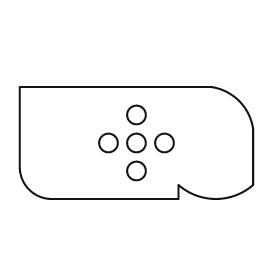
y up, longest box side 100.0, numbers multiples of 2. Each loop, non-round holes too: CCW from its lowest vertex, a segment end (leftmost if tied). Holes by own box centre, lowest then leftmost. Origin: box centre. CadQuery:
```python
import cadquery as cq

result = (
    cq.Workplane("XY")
    .moveTo(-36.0, -24.0)
    .lineTo(18.0, -24.0)
    .lineTo(18.0, -18.0)
    .threePointArc((34.0, -24.0), (50.0, -18.0))
    .lineTo(50.0, 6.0)
    .threePointArc((44.0, 18.0), (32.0, 24.0))
    .lineTo(-50.0, 24.0)
    .lineTo(-50.0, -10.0)
    .threePointArc((-46.0, -20.0), (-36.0, -24.0))
    .close()
    .moveTo(0.0, -12.0)
    .circle(4.0)
    .moveTo(-12.0, 0.0)
    .circle(4.0)
    .moveTo(0.0, 0.0)
    .circle(4.0)
    .moveTo(12.0, 0.0)
    .circle(4.0)
    .moveTo(0.0, 12.0)
    .circle(4.0)
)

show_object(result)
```